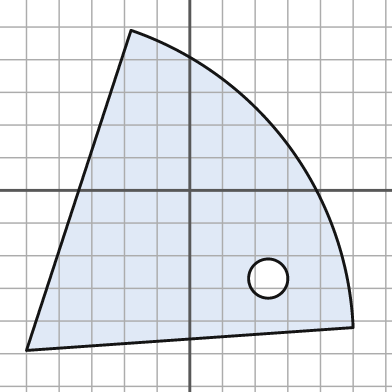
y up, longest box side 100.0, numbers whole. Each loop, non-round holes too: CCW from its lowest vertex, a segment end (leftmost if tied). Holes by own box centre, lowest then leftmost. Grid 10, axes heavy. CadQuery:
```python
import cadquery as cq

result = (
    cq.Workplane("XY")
    .moveTo(-50.0, -49.0)
    .lineTo(50.0, -42.0)
    .threePointArc((30.0, 14.0), (-18.0, 49.0))
    .close()
    .moveTo(24.0, -27.0)
    .circle(6.0)
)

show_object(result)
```